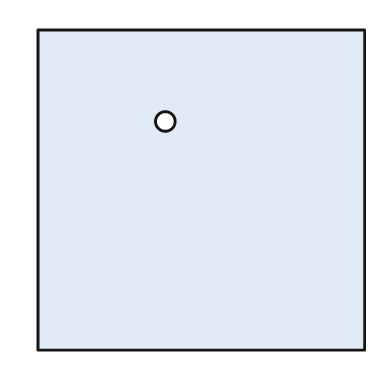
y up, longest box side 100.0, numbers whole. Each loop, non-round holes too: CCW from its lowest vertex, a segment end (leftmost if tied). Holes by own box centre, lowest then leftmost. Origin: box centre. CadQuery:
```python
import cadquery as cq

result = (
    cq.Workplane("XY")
    .moveTo(-50.0, -49.0)
    .lineTo(50.0, -49.0)
    .lineTo(50.0, 49.0)
    .lineTo(-50.0, 49.0)
    .close()
    .moveTo(-11.0, 21.0)
    .circle(3.0)
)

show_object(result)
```